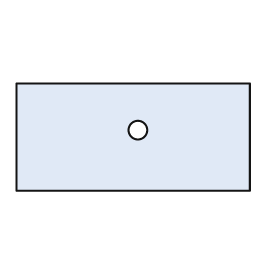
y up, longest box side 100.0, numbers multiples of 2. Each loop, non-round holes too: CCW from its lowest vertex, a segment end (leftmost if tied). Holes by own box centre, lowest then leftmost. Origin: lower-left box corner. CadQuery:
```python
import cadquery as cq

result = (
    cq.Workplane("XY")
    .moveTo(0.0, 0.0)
    .lineTo(100.0, 0.0)
    .lineTo(100.0, 46.0)
    .lineTo(0.0, 46.0)
    .close()
    .moveTo(52.0, 26.0)
    .circle(4.0)
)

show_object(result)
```